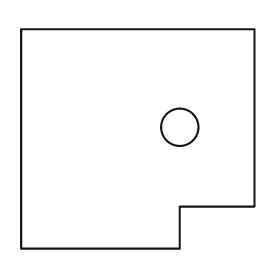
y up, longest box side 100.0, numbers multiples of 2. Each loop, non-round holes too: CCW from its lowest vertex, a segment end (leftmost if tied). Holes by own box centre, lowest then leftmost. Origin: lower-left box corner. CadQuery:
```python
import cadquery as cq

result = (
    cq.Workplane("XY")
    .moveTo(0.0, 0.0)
    .lineTo(68.0, 0.0)
    .lineTo(68.0, 18.0)
    .lineTo(100.0, 18.0)
    .lineTo(100.0, 94.0)
    .lineTo(0.0, 94.0)
    .close()
    .moveTo(68.0, 52.0)
    .circle(8.0)
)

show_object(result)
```